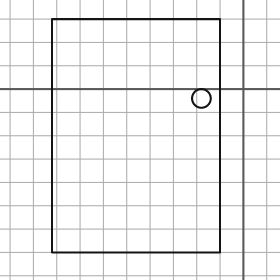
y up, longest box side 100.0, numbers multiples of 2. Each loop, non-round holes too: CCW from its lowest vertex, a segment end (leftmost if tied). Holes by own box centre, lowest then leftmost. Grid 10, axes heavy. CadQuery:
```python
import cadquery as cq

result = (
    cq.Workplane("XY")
    .moveTo(-82.0, -70.0)
    .lineTo(-10.0, -70.0)
    .lineTo(-10.0, 30.0)
    .lineTo(-82.0, 30.0)
    .close()
    .moveTo(-18.0, -4.0)
    .circle(4.0)
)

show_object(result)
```